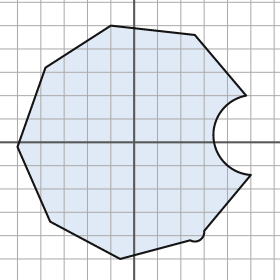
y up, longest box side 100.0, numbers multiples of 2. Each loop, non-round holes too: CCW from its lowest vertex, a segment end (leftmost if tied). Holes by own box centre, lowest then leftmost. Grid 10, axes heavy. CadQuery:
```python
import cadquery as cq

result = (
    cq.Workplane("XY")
    .moveTo(-6.0, -50.0)
    .lineTo(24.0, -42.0)
    .threePointArc((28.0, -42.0), (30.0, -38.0))
    .lineTo(50.0, -14.0)
    .threePointArc((34.0, 2.0), (48.0, 20.0))
    .lineTo(26.0, 46.0)
    .lineTo(-10.0, 50.0)
    .lineTo(-38.0, 32.0)
    .lineTo(-50.0, -2.0)
    .lineTo(-36.0, -34.0)
    .close()
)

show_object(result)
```